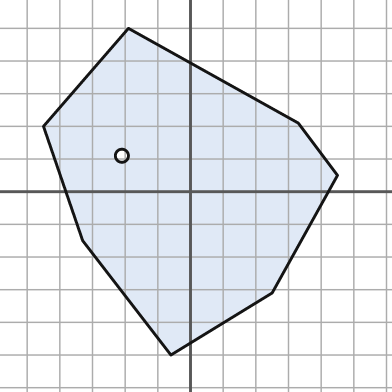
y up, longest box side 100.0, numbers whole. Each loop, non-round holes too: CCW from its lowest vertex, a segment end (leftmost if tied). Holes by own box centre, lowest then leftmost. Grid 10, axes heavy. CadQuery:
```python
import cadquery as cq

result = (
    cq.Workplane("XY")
    .moveTo(-6.0, -50.0)
    .lineTo(25.0, -31.0)
    .lineTo(45.0, 5.0)
    .lineTo(33.0, 21.0)
    .lineTo(-19.0, 50.0)
    .lineTo(-45.0, 20.0)
    .lineTo(-33.0, -15.0)
    .close()
    .moveTo(-21.0, 11.0)
    .circle(2.0)
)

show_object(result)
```